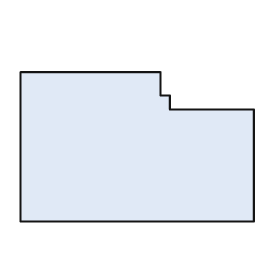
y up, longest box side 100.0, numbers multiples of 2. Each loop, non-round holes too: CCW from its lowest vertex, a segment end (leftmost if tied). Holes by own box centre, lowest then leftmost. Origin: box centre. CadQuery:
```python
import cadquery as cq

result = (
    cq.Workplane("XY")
    .moveTo(-50.0, -32.0)
    .lineTo(50.0, -32.0)
    .lineTo(50.0, 16.0)
    .lineTo(14.0, 16.0)
    .lineTo(14.0, 22.0)
    .lineTo(10.0, 22.0)
    .lineTo(10.0, 32.0)
    .lineTo(-50.0, 32.0)
    .close()
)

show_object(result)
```